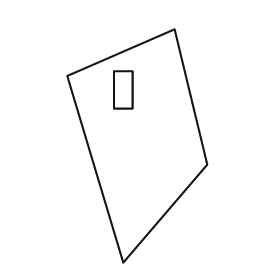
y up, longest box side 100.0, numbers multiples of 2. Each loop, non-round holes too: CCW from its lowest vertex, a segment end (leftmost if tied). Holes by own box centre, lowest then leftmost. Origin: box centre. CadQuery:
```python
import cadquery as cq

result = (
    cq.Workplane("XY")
    .moveTo(-6.0, -50.0)
    .lineTo(30.0, -8.0)
    .lineTo(16.0, 50.0)
    .lineTo(-30.0, 30.0)
    .close()
    .moveTo(-10.0, 16.0)
    .lineTo(-2.0, 16.0)
    .lineTo(-2.0, 32.0)
    .lineTo(-10.0, 32.0)
    .close()
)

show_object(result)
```